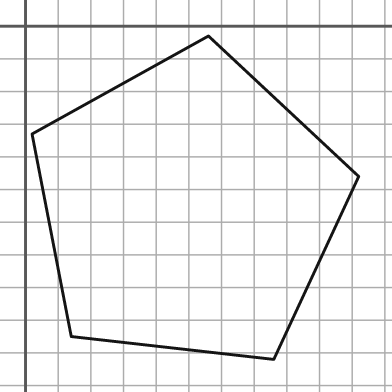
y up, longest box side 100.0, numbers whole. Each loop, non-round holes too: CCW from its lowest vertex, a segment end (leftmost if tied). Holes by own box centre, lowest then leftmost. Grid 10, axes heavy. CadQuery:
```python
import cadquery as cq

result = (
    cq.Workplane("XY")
    .moveTo(76.0, -102.0)
    .lineTo(102.0, -46.0)
    .lineTo(56.0, -3.0)
    .lineTo(2.0, -33.0)
    .lineTo(14.0, -95.0)
    .close()
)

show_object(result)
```